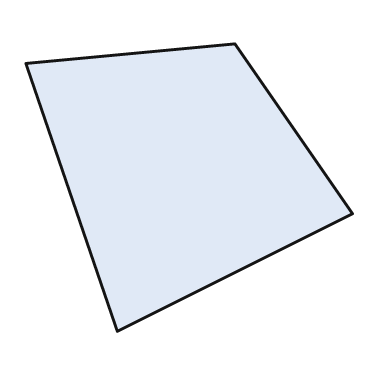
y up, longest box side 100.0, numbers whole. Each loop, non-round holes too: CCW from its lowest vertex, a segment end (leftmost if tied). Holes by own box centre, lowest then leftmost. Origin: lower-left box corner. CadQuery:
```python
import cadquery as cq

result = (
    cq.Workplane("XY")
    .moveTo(28.0, 0.0)
    .lineTo(100.0, 36.0)
    .lineTo(64.0, 88.0)
    .lineTo(0.0, 82.0)
    .close()
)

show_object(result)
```